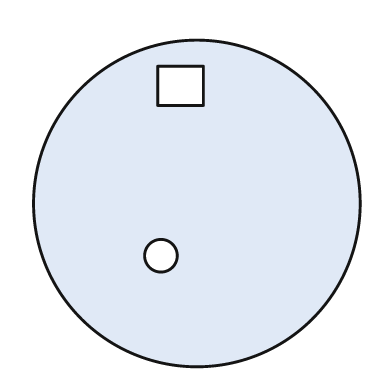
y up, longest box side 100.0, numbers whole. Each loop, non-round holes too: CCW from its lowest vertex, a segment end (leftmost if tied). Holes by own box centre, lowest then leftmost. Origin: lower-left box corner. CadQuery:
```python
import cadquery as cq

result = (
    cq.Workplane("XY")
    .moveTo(50.0, 50.0)
    .circle(50.0)
    .moveTo(39.0, 34.0)
    .circle(5.0)
    .moveTo(38.0, 80.0)
    .lineTo(52.0, 80.0)
    .lineTo(52.0, 92.0)
    .lineTo(38.0, 92.0)
    .close()
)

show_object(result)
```